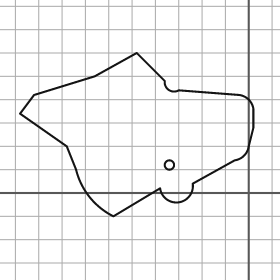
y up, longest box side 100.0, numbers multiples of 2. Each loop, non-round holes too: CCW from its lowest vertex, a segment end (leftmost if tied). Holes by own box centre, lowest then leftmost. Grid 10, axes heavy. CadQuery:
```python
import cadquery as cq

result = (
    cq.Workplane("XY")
    .moveTo(-58.0, -10.0)
    .lineTo(-38.0, 2.0)
    .threePointArc((-30.0, -4.0), (-24.0, 4.0))
    .lineTo(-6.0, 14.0)
    .threePointArc((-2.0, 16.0), (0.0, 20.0))
    .lineTo(2.0, 28.0)
    .lineTo(2.0, 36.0)
    .threePointArc((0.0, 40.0), (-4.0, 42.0))
    .lineTo(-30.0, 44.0)
    .threePointArc((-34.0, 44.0), (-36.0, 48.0))
    .lineTo(-48.0, 60.0)
    .lineTo(-66.0, 50.0)
    .lineTo(-92.0, 42.0)
    .lineTo(-98.0, 34.0)
    .lineTo(-78.0, 20.0)
    .lineTo(-74.0, 10.0)
    .threePointArc((-68.0, -2.0), (-58.0, -10.0))
    .close()
    .moveTo(-34.0, 12.0)
    .circle(2.0)
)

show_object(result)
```